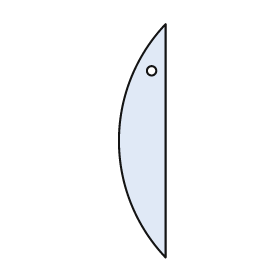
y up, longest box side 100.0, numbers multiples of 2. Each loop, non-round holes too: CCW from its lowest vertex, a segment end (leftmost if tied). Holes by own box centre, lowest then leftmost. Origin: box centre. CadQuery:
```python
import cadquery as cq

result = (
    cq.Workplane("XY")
    .moveTo(10.0, -50.0)
    .lineTo(10.0, 50.0)
    .threePointArc((-10.0, 0.0), (10.0, -50.0))
    .close()
    .moveTo(4.0, 30.0)
    .circle(2.0)
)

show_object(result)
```